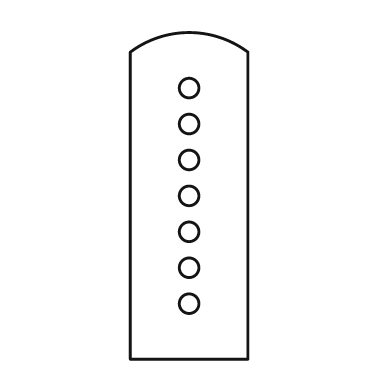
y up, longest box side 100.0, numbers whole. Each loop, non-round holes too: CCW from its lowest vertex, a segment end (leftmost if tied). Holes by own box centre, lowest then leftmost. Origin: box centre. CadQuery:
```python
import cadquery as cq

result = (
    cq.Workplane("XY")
    .moveTo(-18.0, -50.0)
    .lineTo(18.0, -50.0)
    .lineTo(18.0, 44.0)
    .threePointArc((0.0, 50.0), (-18.0, 44.0))
    .close()
    .moveTo(0.0, -33.0)
    .circle(3.0)
    .moveTo(0.0, -22.0)
    .circle(3.0)
    .moveTo(0.0, -11.0)
    .circle(3.0)
    .moveTo(0.0, 0.0)
    .circle(3.0)
    .moveTo(0.0, 11.0)
    .circle(3.0)
    .moveTo(0.0, 22.0)
    .circle(3.0)
    .moveTo(0.0, 33.0)
    .circle(3.0)
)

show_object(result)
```